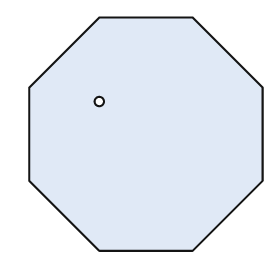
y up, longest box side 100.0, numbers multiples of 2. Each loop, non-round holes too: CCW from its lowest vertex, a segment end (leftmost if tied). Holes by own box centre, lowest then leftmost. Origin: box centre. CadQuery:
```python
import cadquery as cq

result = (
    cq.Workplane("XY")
    .moveTo(-20.0, -50.0)
    .lineTo(20.0, -50.0)
    .lineTo(50.0, -20.0)
    .lineTo(50.0, 20.0)
    .lineTo(20.0, 50.0)
    .lineTo(-20.0, 50.0)
    .lineTo(-50.0, 20.0)
    .lineTo(-50.0, -20.0)
    .close()
    .moveTo(-20.0, 14.0)
    .circle(2.0)
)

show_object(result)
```